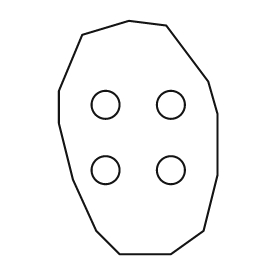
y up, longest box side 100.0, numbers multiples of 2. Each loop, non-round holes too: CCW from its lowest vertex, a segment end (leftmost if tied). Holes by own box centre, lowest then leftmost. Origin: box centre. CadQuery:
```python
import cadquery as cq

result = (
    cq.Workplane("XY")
    .moveTo(-8.0, -50.0)
    .lineTo(14.0, -50.0)
    .lineTo(28.0, -40.0)
    .lineTo(34.0, -16.0)
    .lineTo(34.0, 10.0)
    .lineTo(30.0, 24.0)
    .lineTo(12.0, 48.0)
    .lineTo(-4.0, 50.0)
    .lineTo(-24.0, 44.0)
    .lineTo(-34.0, 20.0)
    .lineTo(-34.0, 6.0)
    .lineTo(-28.0, -18.0)
    .lineTo(-18.0, -40.0)
    .close()
    .moveTo(-14.0, -14.0)
    .circle(6.0)
    .moveTo(14.0, -14.0)
    .circle(6.0)
    .moveTo(-14.0, 14.0)
    .circle(6.0)
    .moveTo(14.0, 14.0)
    .circle(6.0)
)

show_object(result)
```